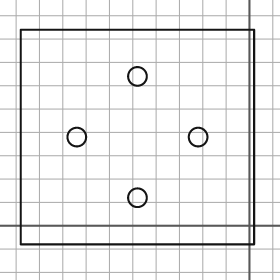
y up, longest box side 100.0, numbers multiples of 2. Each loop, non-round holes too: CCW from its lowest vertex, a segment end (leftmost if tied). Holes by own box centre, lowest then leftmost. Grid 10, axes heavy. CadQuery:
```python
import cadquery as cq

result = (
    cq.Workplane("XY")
    .moveTo(-98.0, -8.0)
    .lineTo(2.0, -8.0)
    .lineTo(2.0, 84.0)
    .lineTo(-98.0, 84.0)
    .close()
    .moveTo(-48.0, 12.0)
    .circle(4.0)
    .moveTo(-74.0, 38.0)
    .circle(4.0)
    .moveTo(-22.0, 38.0)
    .circle(4.0)
    .moveTo(-48.0, 64.0)
    .circle(4.0)
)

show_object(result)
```